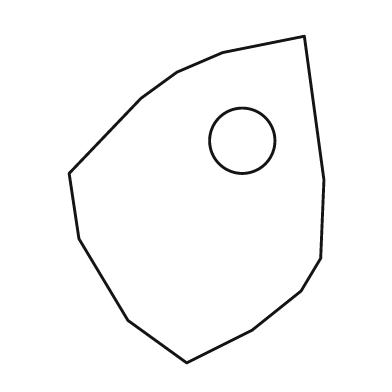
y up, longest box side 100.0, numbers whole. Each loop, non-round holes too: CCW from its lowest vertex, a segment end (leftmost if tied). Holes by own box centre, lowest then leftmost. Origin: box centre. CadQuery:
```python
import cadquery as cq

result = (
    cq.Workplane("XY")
    .moveTo(-3.0, -50.0)
    .lineTo(17.0, -40.0)
    .lineTo(32.0, -28.0)
    .lineTo(38.0, -18.0)
    .lineTo(39.0, 6.0)
    .lineTo(33.0, 50.0)
    .lineTo(8.0, 45.0)
    .lineTo(-6.0, 39.0)
    .lineTo(-17.0, 31.0)
    .lineTo(-39.0, 8.0)
    .lineTo(-36.0, -12.0)
    .lineTo(-21.0, -37.0)
    .close()
    .moveTo(14.0, 18.0)
    .circle(10.0)
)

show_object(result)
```